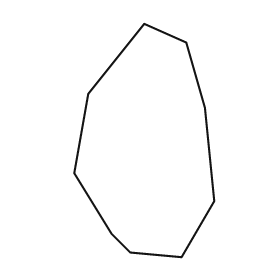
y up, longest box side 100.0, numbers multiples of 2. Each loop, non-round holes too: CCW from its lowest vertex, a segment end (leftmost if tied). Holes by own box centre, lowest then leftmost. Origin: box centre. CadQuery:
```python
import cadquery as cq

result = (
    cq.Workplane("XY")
    .moveTo(16.0, -50.0)
    .lineTo(30.0, -26.0)
    .lineTo(26.0, 14.0)
    .lineTo(18.0, 42.0)
    .lineTo(0.0, 50.0)
    .lineTo(-24.0, 20.0)
    .lineTo(-30.0, -14.0)
    .lineTo(-14.0, -40.0)
    .lineTo(-6.0, -48.0)
    .close()
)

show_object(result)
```